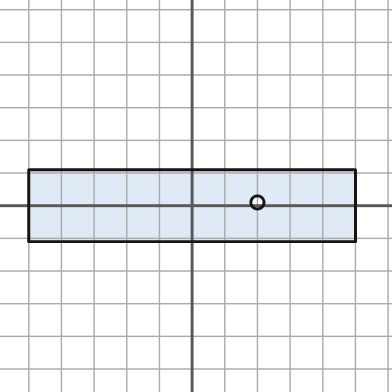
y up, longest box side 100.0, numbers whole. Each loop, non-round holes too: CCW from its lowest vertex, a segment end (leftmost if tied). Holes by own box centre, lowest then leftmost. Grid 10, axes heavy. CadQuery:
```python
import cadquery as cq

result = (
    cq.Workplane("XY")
    .moveTo(-50.0, -11.0)
    .lineTo(50.0, -11.0)
    .lineTo(50.0, 11.0)
    .lineTo(-50.0, 11.0)
    .close()
    .moveTo(20.0, 1.0)
    .circle(2.0)
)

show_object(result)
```